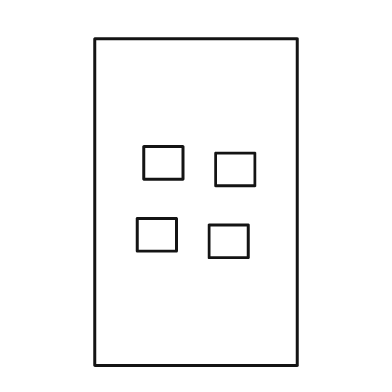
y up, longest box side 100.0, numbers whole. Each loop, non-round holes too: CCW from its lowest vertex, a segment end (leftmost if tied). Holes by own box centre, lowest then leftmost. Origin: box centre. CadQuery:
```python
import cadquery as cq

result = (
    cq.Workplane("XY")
    .moveTo(-31.0, -50.0)
    .lineTo(31.0, -50.0)
    .lineTo(31.0, 50.0)
    .lineTo(-31.0, 50.0)
    .close()
    .moveTo(4.0, -17.0)
    .lineTo(16.0, -17.0)
    .lineTo(16.0, -7.0)
    .lineTo(4.0, -7.0)
    .close()
    .moveTo(-18.0, -15.0)
    .lineTo(-6.0, -15.0)
    .lineTo(-6.0, -5.0)
    .lineTo(-18.0, -5.0)
    .close()
    .moveTo(6.0, 5.0)
    .lineTo(18.0, 5.0)
    .lineTo(18.0, 15.0)
    .lineTo(6.0, 15.0)
    .close()
    .moveTo(-16.0, 7.0)
    .lineTo(-4.0, 7.0)
    .lineTo(-4.0, 17.0)
    .lineTo(-16.0, 17.0)
    .close()
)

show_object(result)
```